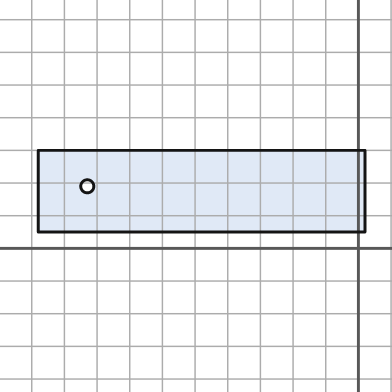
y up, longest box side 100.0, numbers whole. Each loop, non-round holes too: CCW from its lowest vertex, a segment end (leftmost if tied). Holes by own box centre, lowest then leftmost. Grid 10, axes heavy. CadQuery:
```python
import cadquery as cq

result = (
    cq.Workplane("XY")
    .moveTo(-98.0, 5.0)
    .lineTo(2.0, 5.0)
    .lineTo(2.0, 30.0)
    .lineTo(-98.0, 30.0)
    .close()
    .moveTo(-83.0, 19.0)
    .circle(2.0)
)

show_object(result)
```